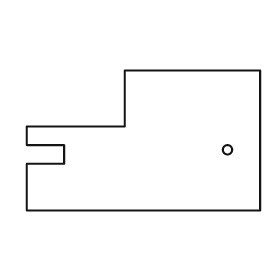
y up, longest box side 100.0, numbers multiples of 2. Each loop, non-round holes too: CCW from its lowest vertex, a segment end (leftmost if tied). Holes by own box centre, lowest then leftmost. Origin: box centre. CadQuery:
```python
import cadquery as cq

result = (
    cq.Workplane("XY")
    .moveTo(-50.0, -30.0)
    .lineTo(50.0, -30.0)
    .lineTo(50.0, 30.0)
    .lineTo(-8.0, 30.0)
    .lineTo(-8.0, 6.0)
    .lineTo(-50.0, 6.0)
    .lineTo(-50.0, -2.0)
    .lineTo(-34.0, -2.0)
    .lineTo(-34.0, -10.0)
    .lineTo(-50.0, -10.0)
    .close()
    .moveTo(36.0, -4.0)
    .circle(2.0)
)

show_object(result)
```